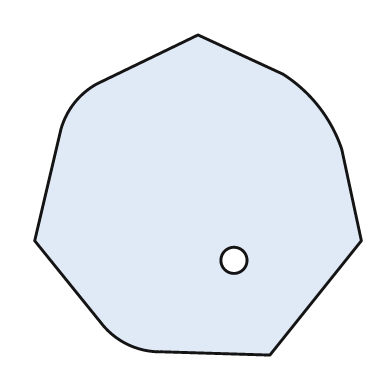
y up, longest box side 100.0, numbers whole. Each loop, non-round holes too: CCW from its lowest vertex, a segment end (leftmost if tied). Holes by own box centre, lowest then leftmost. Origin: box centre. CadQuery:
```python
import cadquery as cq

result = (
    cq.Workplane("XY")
    .moveTo(22.0, -49.0)
    .lineTo(50.0, -14.0)
    .lineTo(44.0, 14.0)
    .threePointArc((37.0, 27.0), (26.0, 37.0))
    .lineTo(0.0, 49.0)
    .lineTo(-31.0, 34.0)
    .threePointArc((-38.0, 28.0), (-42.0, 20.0))
    .lineTo(-50.0, -14.0)
    .lineTo(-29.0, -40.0)
    .threePointArc((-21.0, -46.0), (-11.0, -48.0))
    .close()
    .moveTo(11.0, -20.0)
    .circle(4.0)
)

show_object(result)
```